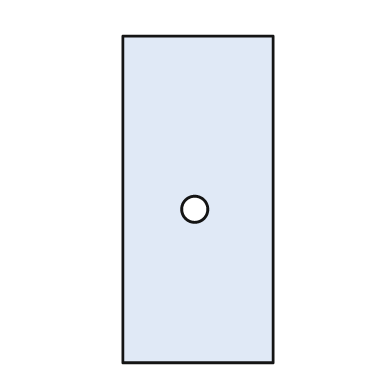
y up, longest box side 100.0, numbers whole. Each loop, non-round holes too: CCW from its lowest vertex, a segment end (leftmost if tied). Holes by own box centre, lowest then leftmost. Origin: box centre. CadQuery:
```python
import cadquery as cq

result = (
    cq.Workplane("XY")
    .moveTo(-23.0, -50.0)
    .lineTo(23.0, -50.0)
    .lineTo(23.0, 50.0)
    .lineTo(-23.0, 50.0)
    .close()
    .moveTo(-1.0, -3.0)
    .circle(4.0)
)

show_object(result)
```